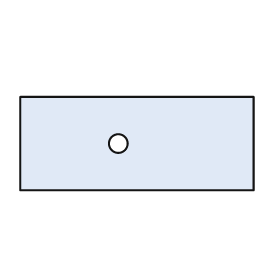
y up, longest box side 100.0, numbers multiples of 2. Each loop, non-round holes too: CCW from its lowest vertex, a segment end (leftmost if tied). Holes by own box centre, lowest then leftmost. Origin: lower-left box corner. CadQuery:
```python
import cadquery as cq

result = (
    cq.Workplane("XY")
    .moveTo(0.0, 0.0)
    .lineTo(100.0, 0.0)
    .lineTo(100.0, 40.0)
    .lineTo(0.0, 40.0)
    .close()
    .moveTo(42.0, 20.0)
    .circle(4.0)
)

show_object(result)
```